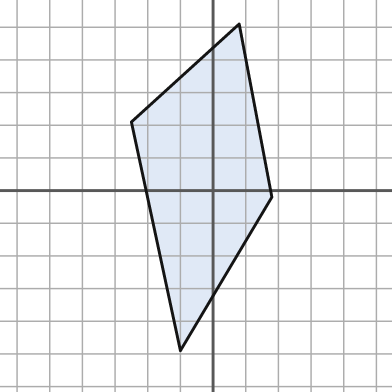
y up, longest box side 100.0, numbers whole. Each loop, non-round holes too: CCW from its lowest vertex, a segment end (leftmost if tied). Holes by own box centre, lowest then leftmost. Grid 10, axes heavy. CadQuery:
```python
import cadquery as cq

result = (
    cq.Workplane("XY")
    .moveTo(-10.0, -49.0)
    .lineTo(18.0, -2.0)
    .lineTo(8.0, 51.0)
    .lineTo(-25.0, 21.0)
    .close()
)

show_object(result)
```